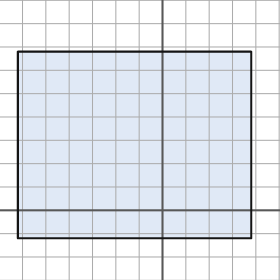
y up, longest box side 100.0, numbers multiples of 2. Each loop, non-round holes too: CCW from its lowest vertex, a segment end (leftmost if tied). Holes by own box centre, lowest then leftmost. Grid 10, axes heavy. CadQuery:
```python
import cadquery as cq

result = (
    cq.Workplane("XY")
    .moveTo(-62.0, -12.0)
    .lineTo(38.0, -12.0)
    .lineTo(38.0, 68.0)
    .lineTo(-62.0, 68.0)
    .close()
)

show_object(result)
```